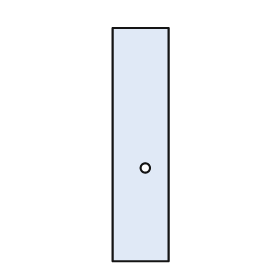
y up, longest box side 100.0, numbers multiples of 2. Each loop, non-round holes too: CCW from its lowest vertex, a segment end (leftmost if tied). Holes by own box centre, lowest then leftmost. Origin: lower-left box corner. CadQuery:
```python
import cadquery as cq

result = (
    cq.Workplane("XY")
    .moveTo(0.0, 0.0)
    .lineTo(24.0, 0.0)
    .lineTo(24.0, 100.0)
    .lineTo(0.0, 100.0)
    .close()
    .moveTo(14.0, 40.0)
    .circle(2.0)
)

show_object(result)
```